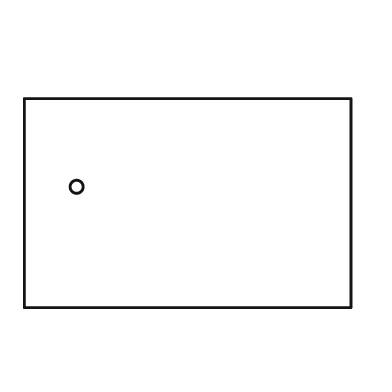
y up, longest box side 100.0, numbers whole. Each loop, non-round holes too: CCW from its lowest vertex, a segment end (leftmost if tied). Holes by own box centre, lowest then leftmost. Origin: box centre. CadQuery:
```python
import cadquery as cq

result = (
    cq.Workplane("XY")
    .moveTo(-50.0, -32.0)
    .lineTo(50.0, -32.0)
    .lineTo(50.0, 32.0)
    .lineTo(-50.0, 32.0)
    .close()
    .moveTo(-34.0, 5.0)
    .circle(2.0)
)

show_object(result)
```